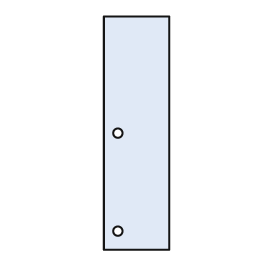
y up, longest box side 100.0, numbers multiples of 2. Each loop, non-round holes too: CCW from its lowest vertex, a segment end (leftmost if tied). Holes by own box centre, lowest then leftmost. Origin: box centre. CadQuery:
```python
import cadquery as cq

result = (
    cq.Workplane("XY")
    .moveTo(-14.0, -50.0)
    .lineTo(14.0, -50.0)
    .lineTo(14.0, 50.0)
    .lineTo(-14.0, 50.0)
    .close()
    .moveTo(-8.0, -42.0)
    .circle(2.0)
    .moveTo(-8.0, 0.0)
    .circle(2.0)
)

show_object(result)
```